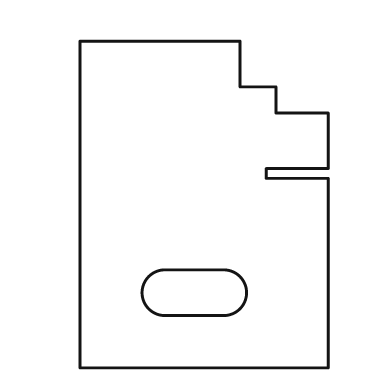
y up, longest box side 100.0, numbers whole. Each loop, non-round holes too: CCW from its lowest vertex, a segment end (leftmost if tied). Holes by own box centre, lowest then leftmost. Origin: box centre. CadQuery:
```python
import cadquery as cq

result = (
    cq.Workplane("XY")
    .moveTo(-38.0, -50.0)
    .lineTo(38.0, -50.0)
    .lineTo(38.0, 8.0)
    .lineTo(19.0, 8.0)
    .lineTo(19.0, 11.0)
    .lineTo(38.0, 11.0)
    .lineTo(38.0, 28.0)
    .lineTo(22.0, 28.0)
    .lineTo(22.0, 36.0)
    .lineTo(11.0, 36.0)
    .lineTo(11.0, 50.0)
    .lineTo(-38.0, 50.0)
    .close()
    .moveTo(-12.0, -34.0)
    .lineTo(6.0, -34.0)
    .threePointArc((13.0, -27.0), (6.0, -20.0))
    .lineTo(-12.0, -20.0)
    .threePointArc((-19.0, -27.0), (-12.0, -34.0))
    .close()
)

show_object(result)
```